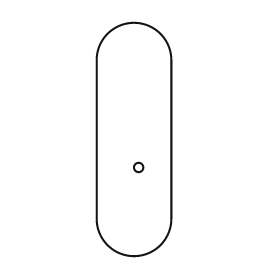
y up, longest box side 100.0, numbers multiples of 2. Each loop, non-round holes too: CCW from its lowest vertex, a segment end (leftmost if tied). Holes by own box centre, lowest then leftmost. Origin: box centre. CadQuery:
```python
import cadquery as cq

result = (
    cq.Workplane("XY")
    .moveTo(-16.0, -34.0)
    .threePointArc((0.0, -50.0), (16.0, -34.0))
    .lineTo(16.0, 34.0)
    .threePointArc((0.0, 50.0), (-16.0, 34.0))
    .close()
    .moveTo(2.0, -12.0)
    .circle(2.0)
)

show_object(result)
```